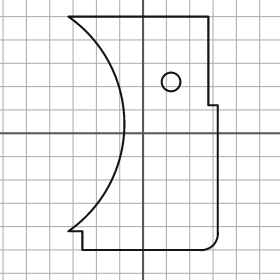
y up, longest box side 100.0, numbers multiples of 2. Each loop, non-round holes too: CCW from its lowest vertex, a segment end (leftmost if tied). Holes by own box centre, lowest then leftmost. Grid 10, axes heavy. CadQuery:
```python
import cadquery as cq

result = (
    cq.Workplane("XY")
    .moveTo(-26.0, -50.0)
    .lineTo(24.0, -50.0)
    .threePointArc((30.0, -48.0), (32.0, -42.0))
    .lineTo(32.0, 12.0)
    .lineTo(28.0, 12.0)
    .lineTo(28.0, 50.0)
    .lineTo(-32.0, 50.0)
    .threePointArc((-8.0, 4.0), (-32.0, -42.0))
    .lineTo(-26.0, -42.0)
    .close()
    .moveTo(12.0, 22.0)
    .circle(4.0)
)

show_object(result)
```